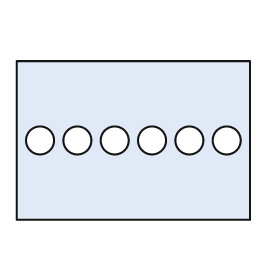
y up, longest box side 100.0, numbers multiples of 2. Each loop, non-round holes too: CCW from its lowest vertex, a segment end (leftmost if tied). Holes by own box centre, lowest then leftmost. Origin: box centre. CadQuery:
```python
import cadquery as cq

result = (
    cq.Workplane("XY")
    .moveTo(-50.0, -34.0)
    .lineTo(50.0, -34.0)
    .lineTo(50.0, 34.0)
    .lineTo(-50.0, 34.0)
    .close()
    .moveTo(-40.0, 0.0)
    .circle(6.0)
    .moveTo(-24.0, 0.0)
    .circle(6.0)
    .moveTo(-8.0, 0.0)
    .circle(6.0)
    .moveTo(8.0, 0.0)
    .circle(6.0)
    .moveTo(24.0, 0.0)
    .circle(6.0)
    .moveTo(40.0, 0.0)
    .circle(6.0)
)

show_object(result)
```